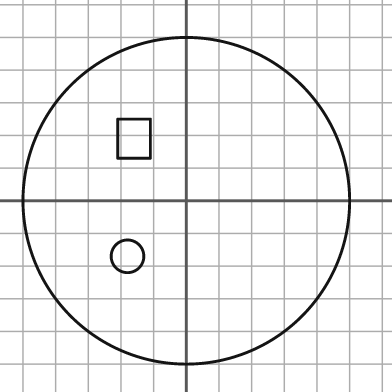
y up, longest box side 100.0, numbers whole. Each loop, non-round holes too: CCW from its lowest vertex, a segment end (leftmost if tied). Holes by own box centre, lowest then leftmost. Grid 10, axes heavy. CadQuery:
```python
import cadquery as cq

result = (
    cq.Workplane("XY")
    .moveTo(0.0, 0.0)
    .circle(50.0)
    .moveTo(-18.0, -17.0)
    .circle(5.0)
    .moveTo(-21.0, 13.0)
    .lineTo(-11.0, 13.0)
    .lineTo(-11.0, 25.0)
    .lineTo(-21.0, 25.0)
    .close()
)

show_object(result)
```